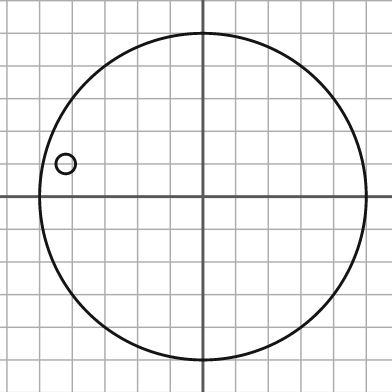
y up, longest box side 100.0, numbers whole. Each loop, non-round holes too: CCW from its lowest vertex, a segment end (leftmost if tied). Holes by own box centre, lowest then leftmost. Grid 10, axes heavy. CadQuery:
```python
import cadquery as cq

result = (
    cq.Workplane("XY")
    .moveTo(0.0, 0.0)
    .circle(50.0)
    .moveTo(-42.0, 10.0)
    .circle(3.0)
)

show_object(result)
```